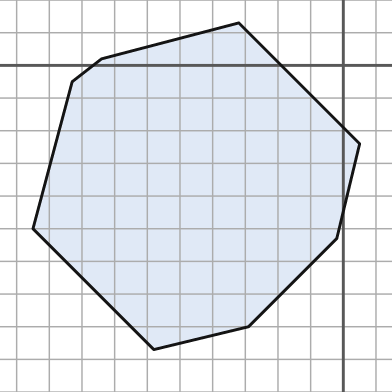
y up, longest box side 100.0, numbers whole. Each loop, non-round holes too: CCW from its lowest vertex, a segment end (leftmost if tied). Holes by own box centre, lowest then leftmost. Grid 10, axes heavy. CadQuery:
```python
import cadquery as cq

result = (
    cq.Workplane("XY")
    .moveTo(-58.0, -87.0)
    .lineTo(-29.0, -80.0)
    .lineTo(-2.0, -53.0)
    .lineTo(5.0, -24.0)
    .lineTo(-32.0, 13.0)
    .lineTo(-74.0, 2.0)
    .lineTo(-83.0, -5.0)
    .lineTo(-95.0, -50.0)
    .close()
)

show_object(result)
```